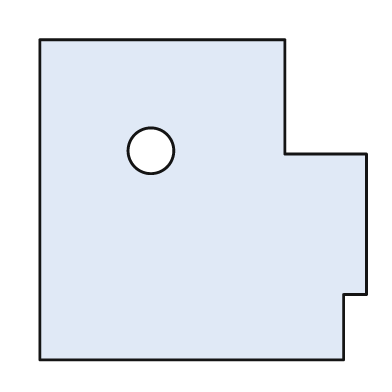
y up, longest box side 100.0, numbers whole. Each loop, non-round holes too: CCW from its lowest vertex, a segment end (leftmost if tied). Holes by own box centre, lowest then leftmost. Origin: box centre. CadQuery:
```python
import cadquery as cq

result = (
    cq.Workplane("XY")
    .moveTo(-50.0, -49.0)
    .lineTo(43.0, -49.0)
    .lineTo(43.0, -29.0)
    .lineTo(50.0, -29.0)
    .lineTo(50.0, 14.0)
    .lineTo(25.0, 14.0)
    .lineTo(25.0, 49.0)
    .lineTo(-50.0, 49.0)
    .close()
    .moveTo(-16.0, 15.0)
    .circle(7.0)
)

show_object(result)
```